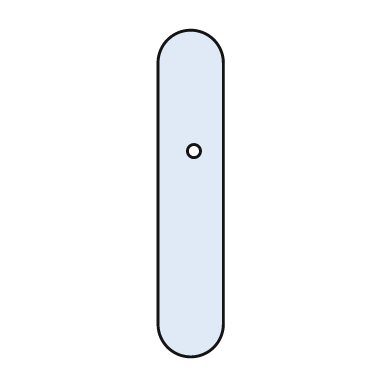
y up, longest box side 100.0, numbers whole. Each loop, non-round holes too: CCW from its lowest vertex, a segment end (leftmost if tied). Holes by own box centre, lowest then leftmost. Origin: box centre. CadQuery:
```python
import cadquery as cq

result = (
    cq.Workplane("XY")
    .moveTo(-10.0, -40.0)
    .threePointArc((0.0, -50.0), (10.0, -40.0))
    .lineTo(10.0, 40.0)
    .threePointArc((0.0, 50.0), (-10.0, 40.0))
    .close()
    .moveTo(1.0, 13.0)
    .circle(2.0)
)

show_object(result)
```